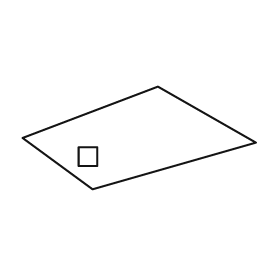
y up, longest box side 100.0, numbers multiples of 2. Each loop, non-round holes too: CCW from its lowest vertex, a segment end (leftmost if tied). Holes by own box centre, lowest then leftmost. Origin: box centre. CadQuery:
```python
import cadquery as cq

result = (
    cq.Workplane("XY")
    .moveTo(-20.0, -22.0)
    .lineTo(50.0, -2.0)
    .lineTo(8.0, 22.0)
    .lineTo(-50.0, 0.0)
    .close()
    .moveTo(-26.0, -12.0)
    .lineTo(-18.0, -12.0)
    .lineTo(-18.0, -4.0)
    .lineTo(-26.0, -4.0)
    .close()
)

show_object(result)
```